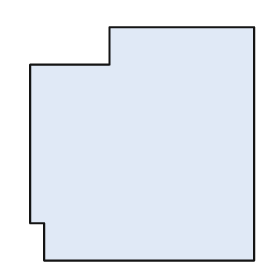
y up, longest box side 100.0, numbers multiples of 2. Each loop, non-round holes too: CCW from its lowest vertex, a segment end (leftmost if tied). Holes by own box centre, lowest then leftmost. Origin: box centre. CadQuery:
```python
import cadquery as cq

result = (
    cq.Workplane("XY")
    .moveTo(-42.0, -50.0)
    .lineTo(48.0, -50.0)
    .lineTo(48.0, 50.0)
    .lineTo(-14.0, 50.0)
    .lineTo(-14.0, 34.0)
    .lineTo(-48.0, 34.0)
    .lineTo(-48.0, -34.0)
    .lineTo(-42.0, -34.0)
    .close()
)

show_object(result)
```